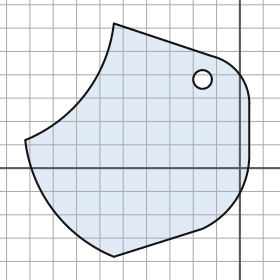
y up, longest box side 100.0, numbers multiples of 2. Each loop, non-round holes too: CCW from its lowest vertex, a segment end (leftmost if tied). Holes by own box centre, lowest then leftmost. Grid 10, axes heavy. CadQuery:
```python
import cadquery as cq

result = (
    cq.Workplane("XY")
    .moveTo(-54.0, -38.0)
    .lineTo(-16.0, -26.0)
    .threePointArc((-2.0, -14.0), (4.0, 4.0))
    .lineTo(4.0, 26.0)
    .threePointArc((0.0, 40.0), (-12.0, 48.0))
    .lineTo(-54.0, 62.0)
    .threePointArc((-66.0, 32.0), (-92.0, 12.0))
    .threePointArc((-80.0, -18.0), (-54.0, -38.0))
    .close()
    .moveTo(-16.0, 38.0)
    .circle(4.0)
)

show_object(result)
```